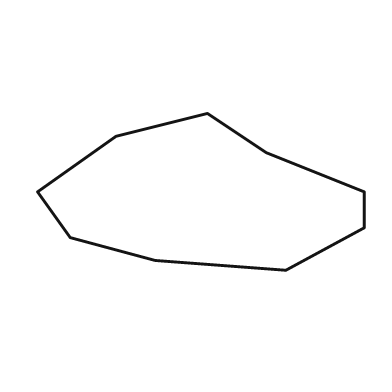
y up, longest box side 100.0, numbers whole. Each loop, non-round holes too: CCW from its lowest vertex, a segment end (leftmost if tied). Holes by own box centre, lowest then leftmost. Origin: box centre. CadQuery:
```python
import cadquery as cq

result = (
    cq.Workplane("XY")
    .moveTo(26.0, -24.0)
    .lineTo(50.0, -11.0)
    .lineTo(50.0, 0.0)
    .lineTo(20.0, 12.0)
    .lineTo(2.0, 24.0)
    .lineTo(-26.0, 17.0)
    .lineTo(-50.0, 0.0)
    .lineTo(-40.0, -14.0)
    .lineTo(-14.0, -21.0)
    .close()
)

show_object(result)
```